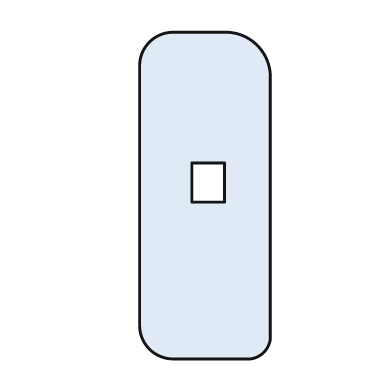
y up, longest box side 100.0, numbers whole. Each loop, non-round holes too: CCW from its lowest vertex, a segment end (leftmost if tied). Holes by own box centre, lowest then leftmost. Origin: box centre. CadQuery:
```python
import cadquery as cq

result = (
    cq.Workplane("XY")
    .moveTo(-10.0, -50.0)
    .lineTo(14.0, -50.0)
    .threePointArc((18.0, -48.0), (20.0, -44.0))
    .lineTo(20.0, 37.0)
    .threePointArc((16.0, 46.0), (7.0, 50.0))
    .lineTo(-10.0, 50.0)
    .threePointArc((-17.0, 47.0), (-20.0, 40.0))
    .lineTo(-20.0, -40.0)
    .threePointArc((-17.0, -47.0), (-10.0, -50.0))
    .close()
    .moveTo(-4.0, -2.0)
    .lineTo(6.0, -2.0)
    .lineTo(6.0, 10.0)
    .lineTo(-4.0, 10.0)
    .close()
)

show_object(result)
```